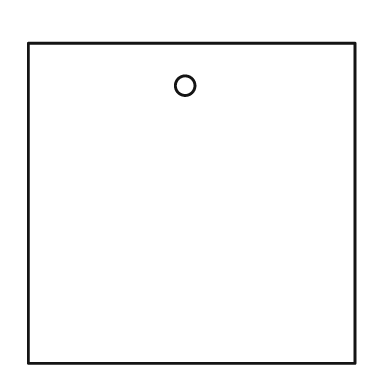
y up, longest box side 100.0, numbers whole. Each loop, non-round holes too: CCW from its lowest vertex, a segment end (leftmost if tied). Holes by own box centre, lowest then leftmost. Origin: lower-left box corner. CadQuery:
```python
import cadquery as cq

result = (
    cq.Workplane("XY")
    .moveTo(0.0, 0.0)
    .lineTo(100.0, 0.0)
    .lineTo(100.0, 98.0)
    .lineTo(0.0, 98.0)
    .close()
    .moveTo(48.0, 85.0)
    .circle(3.0)
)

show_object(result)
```